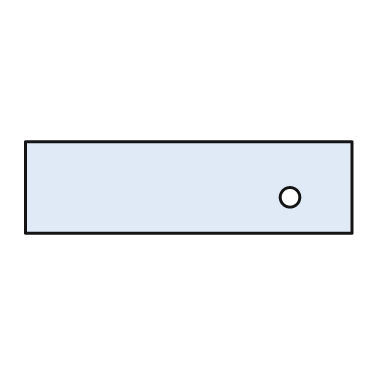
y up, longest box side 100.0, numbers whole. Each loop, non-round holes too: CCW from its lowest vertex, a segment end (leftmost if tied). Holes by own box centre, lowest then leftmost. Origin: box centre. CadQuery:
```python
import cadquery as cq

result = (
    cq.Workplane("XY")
    .moveTo(-50.0, -14.0)
    .lineTo(50.0, -14.0)
    .lineTo(50.0, 14.0)
    .lineTo(-50.0, 14.0)
    .close()
    .moveTo(31.0, -3.0)
    .circle(3.0)
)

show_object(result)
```